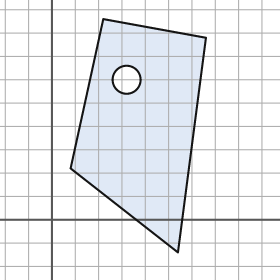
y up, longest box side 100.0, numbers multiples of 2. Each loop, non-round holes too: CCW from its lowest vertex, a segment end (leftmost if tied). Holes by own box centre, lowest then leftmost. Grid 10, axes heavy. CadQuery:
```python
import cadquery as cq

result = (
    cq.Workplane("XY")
    .moveTo(54.0, -14.0)
    .lineTo(66.0, 78.0)
    .lineTo(22.0, 86.0)
    .lineTo(8.0, 22.0)
    .close()
    .moveTo(32.0, 60.0)
    .circle(6.0)
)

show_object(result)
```